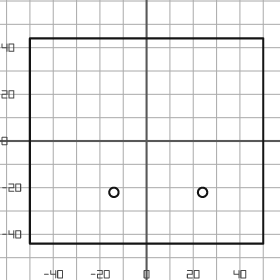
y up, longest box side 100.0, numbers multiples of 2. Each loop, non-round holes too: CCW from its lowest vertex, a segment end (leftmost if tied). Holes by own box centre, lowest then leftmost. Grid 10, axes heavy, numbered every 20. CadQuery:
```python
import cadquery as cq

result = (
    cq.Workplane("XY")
    .moveTo(-50.0, -44.0)
    .lineTo(50.0, -44.0)
    .lineTo(50.0, 44.0)
    .lineTo(-50.0, 44.0)
    .close()
    .moveTo(-14.0, -22.0)
    .circle(2.0)
    .moveTo(24.0, -22.0)
    .circle(2.0)
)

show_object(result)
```